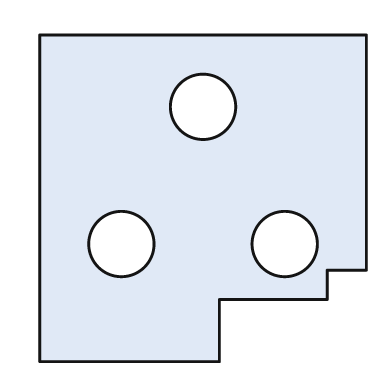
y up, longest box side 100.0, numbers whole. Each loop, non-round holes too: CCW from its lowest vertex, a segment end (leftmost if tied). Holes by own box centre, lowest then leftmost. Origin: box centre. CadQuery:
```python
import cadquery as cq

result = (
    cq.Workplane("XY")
    .moveTo(-50.0, -50.0)
    .lineTo(5.0, -50.0)
    .lineTo(5.0, -31.0)
    .lineTo(38.0, -31.0)
    .lineTo(38.0, -22.0)
    .lineTo(50.0, -22.0)
    .lineTo(50.0, 50.0)
    .lineTo(-50.0, 50.0)
    .close()
    .moveTo(-25.0, -14.0)
    .circle(10.0)
    .moveTo(25.0, -14.0)
    .circle(10.0)
    .moveTo(0.0, 28.0)
    .circle(10.0)
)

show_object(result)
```